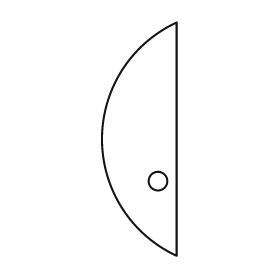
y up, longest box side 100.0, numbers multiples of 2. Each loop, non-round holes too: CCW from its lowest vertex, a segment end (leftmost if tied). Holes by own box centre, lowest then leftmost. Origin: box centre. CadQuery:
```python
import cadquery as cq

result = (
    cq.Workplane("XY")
    .moveTo(16.0, -50.0)
    .lineTo(16.0, 50.0)
    .threePointArc((-16.0, 0.0), (16.0, -50.0))
    .close()
    .moveTo(8.0, -18.0)
    .circle(4.0)
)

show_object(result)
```